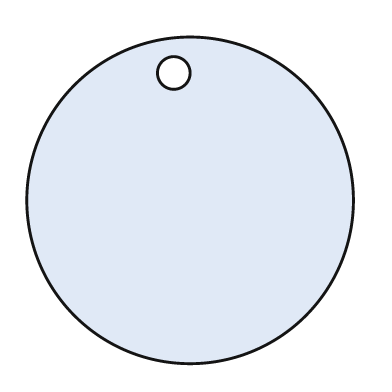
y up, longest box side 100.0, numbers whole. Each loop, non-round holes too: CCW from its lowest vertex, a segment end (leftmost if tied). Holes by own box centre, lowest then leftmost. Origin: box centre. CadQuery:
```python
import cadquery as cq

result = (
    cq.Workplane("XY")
    .moveTo(0.0, 0.0)
    .circle(50.0)
    .moveTo(-5.0, 39.0)
    .circle(5.0)
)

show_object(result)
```